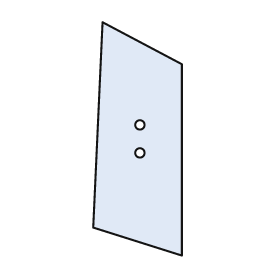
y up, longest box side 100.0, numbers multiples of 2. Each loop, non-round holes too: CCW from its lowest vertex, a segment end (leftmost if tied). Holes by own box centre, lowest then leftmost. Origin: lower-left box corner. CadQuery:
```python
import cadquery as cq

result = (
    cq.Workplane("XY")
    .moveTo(38.0, 0.0)
    .lineTo(38.0, 82.0)
    .lineTo(4.0, 100.0)
    .lineTo(0.0, 12.0)
    .close()
    .moveTo(20.0, 44.0)
    .circle(2.0)
    .moveTo(20.0, 56.0)
    .circle(2.0)
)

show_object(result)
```